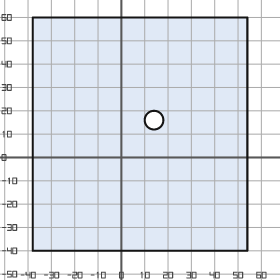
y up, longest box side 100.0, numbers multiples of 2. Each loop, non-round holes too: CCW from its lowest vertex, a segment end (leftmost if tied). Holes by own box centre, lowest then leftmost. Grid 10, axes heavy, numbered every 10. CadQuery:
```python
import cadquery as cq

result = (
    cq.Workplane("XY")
    .moveTo(-38.0, -40.0)
    .lineTo(54.0, -40.0)
    .lineTo(54.0, 60.0)
    .lineTo(-38.0, 60.0)
    .close()
    .moveTo(14.0, 16.0)
    .circle(4.0)
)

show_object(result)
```